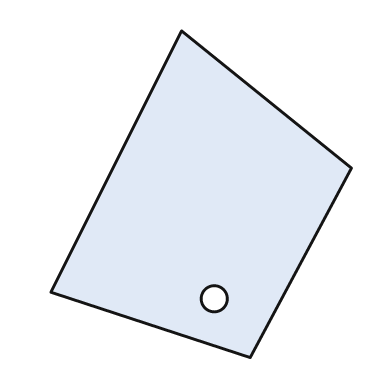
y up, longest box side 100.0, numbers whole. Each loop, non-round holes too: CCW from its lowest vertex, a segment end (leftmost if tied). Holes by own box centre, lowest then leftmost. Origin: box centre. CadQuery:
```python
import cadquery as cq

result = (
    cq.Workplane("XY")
    .moveTo(15.0, -50.0)
    .lineTo(46.0, 8.0)
    .lineTo(-6.0, 50.0)
    .lineTo(-46.0, -30.0)
    .close()
    .moveTo(4.0, -32.0)
    .circle(4.0)
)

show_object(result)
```